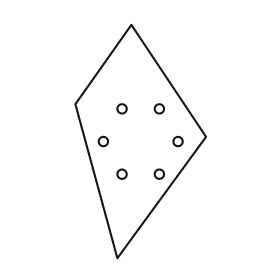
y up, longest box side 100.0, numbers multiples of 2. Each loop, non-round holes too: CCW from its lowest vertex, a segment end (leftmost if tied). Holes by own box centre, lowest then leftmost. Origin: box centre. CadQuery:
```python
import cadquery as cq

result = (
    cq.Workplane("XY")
    .moveTo(-10.0, -50.0)
    .lineTo(28.0, 2.0)
    .lineTo(-4.0, 50.0)
    .lineTo(-28.0, 16.0)
    .close()
    .moveTo(-8.0, -14.0)
    .circle(2.0)
    .moveTo(8.0, -14.0)
    .circle(2.0)
    .moveTo(-16.0, 0.0)
    .circle(2.0)
    .moveTo(16.0, 0.0)
    .circle(2.0)
    .moveTo(-8.0, 14.0)
    .circle(2.0)
    .moveTo(8.0, 14.0)
    .circle(2.0)
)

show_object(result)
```